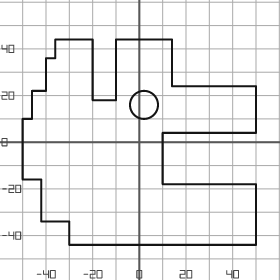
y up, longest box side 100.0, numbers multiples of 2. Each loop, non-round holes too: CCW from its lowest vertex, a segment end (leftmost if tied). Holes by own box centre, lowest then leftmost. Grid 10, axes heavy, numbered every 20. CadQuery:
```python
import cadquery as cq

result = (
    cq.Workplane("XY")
    .moveTo(-30.0, -44.0)
    .lineTo(50.0, -44.0)
    .lineTo(50.0, -18.0)
    .lineTo(10.0, -18.0)
    .lineTo(10.0, 4.0)
    .lineTo(50.0, 4.0)
    .lineTo(50.0, 24.0)
    .lineTo(14.0, 24.0)
    .lineTo(14.0, 44.0)
    .lineTo(-10.0, 44.0)
    .lineTo(-10.0, 18.0)
    .lineTo(-20.0, 18.0)
    .lineTo(-20.0, 44.0)
    .lineTo(-36.0, 44.0)
    .lineTo(-36.0, 36.0)
    .lineTo(-40.0, 36.0)
    .lineTo(-40.0, 22.0)
    .lineTo(-46.0, 22.0)
    .lineTo(-46.0, 10.0)
    .lineTo(-50.0, 10.0)
    .lineTo(-50.0, -16.0)
    .lineTo(-42.0, -16.0)
    .lineTo(-42.0, -34.0)
    .lineTo(-30.0, -34.0)
    .close()
    .moveTo(2.0, 16.0)
    .circle(6.0)
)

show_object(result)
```